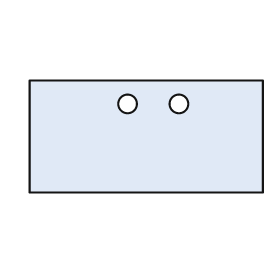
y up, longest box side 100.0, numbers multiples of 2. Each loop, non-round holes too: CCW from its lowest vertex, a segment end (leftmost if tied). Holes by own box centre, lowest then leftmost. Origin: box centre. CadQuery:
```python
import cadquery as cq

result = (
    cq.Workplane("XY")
    .moveTo(-50.0, -24.0)
    .lineTo(50.0, -24.0)
    .lineTo(50.0, 24.0)
    .lineTo(-50.0, 24.0)
    .close()
    .moveTo(-8.0, 14.0)
    .circle(4.0)
    .moveTo(14.0, 14.0)
    .circle(4.0)
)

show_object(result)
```